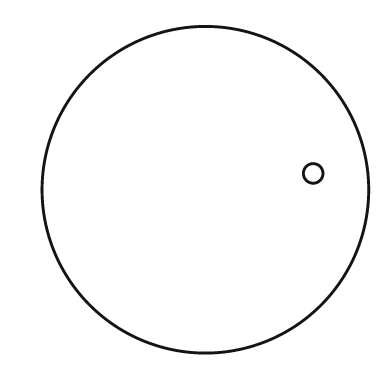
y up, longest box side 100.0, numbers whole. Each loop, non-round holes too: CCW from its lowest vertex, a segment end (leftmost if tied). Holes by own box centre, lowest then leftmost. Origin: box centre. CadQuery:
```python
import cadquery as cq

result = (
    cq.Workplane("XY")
    .moveTo(0.0, 0.0)
    .circle(50.0)
    .moveTo(33.0, 5.0)
    .circle(3.0)
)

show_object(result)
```